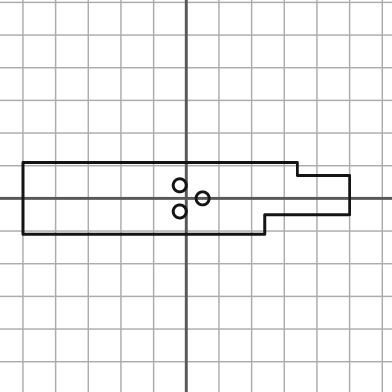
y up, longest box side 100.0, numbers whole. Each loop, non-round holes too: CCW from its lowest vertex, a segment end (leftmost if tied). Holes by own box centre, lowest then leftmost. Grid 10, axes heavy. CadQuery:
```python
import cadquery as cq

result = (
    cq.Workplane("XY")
    .moveTo(-50.0, -11.0)
    .lineTo(24.0, -11.0)
    .lineTo(24.0, -5.0)
    .lineTo(50.0, -5.0)
    .lineTo(50.0, 7.0)
    .lineTo(34.0, 7.0)
    .lineTo(34.0, 11.0)
    .lineTo(-50.0, 11.0)
    .close()
    .moveTo(-2.0, -4.0)
    .circle(2.0)
    .moveTo(5.0, 0.0)
    .circle(2.0)
    .moveTo(-2.0, 4.0)
    .circle(2.0)
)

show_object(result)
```